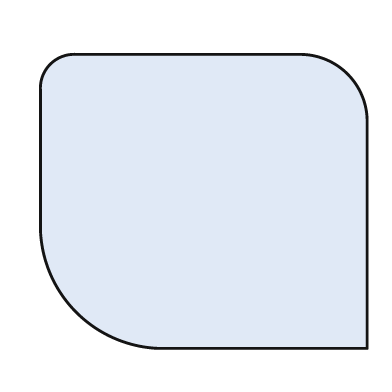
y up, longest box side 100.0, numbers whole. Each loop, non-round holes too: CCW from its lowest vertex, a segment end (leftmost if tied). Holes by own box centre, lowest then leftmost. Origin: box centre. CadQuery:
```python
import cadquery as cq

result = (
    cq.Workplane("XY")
    .moveTo(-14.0, -45.0)
    .lineTo(50.0, -45.0)
    .lineTo(50.0, 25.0)
    .threePointArc((44.0, 39.0), (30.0, 45.0))
    .lineTo(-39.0, 45.0)
    .threePointArc((-47.0, 42.0), (-50.0, 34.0))
    .lineTo(-50.0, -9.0)
    .threePointArc((-39.0, -34.0), (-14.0, -45.0))
    .close()
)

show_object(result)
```